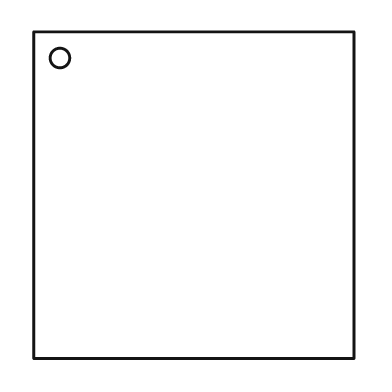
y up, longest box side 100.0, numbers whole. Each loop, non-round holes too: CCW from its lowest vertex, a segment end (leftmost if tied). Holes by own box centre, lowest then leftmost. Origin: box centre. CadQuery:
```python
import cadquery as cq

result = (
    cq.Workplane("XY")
    .moveTo(-49.0, -50.0)
    .lineTo(49.0, -50.0)
    .lineTo(49.0, 50.0)
    .lineTo(-49.0, 50.0)
    .close()
    .moveTo(-41.0, 42.0)
    .circle(3.0)
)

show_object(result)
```